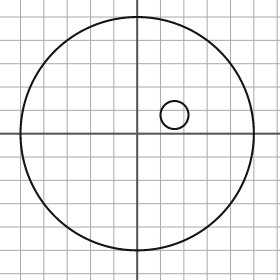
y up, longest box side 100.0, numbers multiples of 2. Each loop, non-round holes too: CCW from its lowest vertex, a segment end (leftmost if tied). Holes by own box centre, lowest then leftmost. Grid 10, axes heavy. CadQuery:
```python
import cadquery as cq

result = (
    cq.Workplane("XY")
    .moveTo(0.0, 0.0)
    .circle(50.0)
    .moveTo(16.0, 8.0)
    .circle(6.0)
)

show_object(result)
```